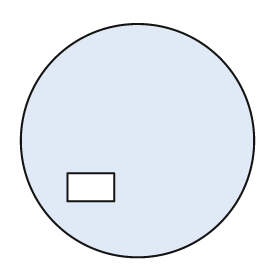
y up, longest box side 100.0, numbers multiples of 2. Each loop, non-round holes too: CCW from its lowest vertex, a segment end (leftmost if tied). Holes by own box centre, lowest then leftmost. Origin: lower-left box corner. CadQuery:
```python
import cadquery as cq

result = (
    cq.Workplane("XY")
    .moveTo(50.0, 50.0)
    .circle(50.0)
    .moveTo(20.0, 24.0)
    .lineTo(40.0, 24.0)
    .lineTo(40.0, 36.0)
    .lineTo(20.0, 36.0)
    .close()
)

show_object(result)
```